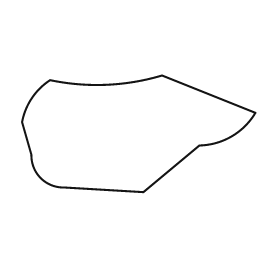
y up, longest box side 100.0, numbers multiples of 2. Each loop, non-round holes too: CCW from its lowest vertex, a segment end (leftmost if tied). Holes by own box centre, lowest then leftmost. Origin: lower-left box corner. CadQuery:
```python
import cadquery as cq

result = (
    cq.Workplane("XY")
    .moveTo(52.0, 0.0)
    .lineTo(76.0, 20.0)
    .threePointArc((90.0, 24.0), (100.0, 34.0))
    .lineTo(60.0, 50.0)
    .threePointArc((36.0, 46.0), (12.0, 48.0))
    .threePointArc((4.0, 40.0), (0.0, 30.0))
    .lineTo(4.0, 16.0)
    .threePointArc((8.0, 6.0), (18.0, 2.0))
    .close()
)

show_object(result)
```